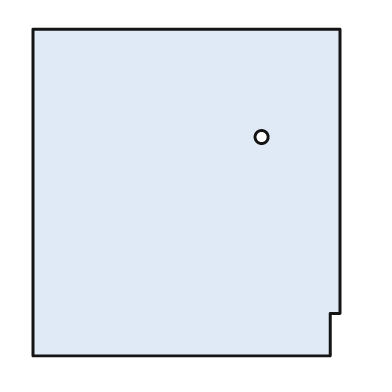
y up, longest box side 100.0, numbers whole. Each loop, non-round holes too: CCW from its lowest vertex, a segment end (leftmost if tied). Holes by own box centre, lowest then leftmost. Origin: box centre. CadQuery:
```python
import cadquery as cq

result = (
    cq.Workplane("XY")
    .moveTo(-47.0, -50.0)
    .lineTo(44.0, -50.0)
    .lineTo(44.0, -37.0)
    .lineTo(47.0, -37.0)
    .lineTo(47.0, 50.0)
    .lineTo(-47.0, 50.0)
    .close()
    .moveTo(23.0, 17.0)
    .circle(2.0)
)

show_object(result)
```